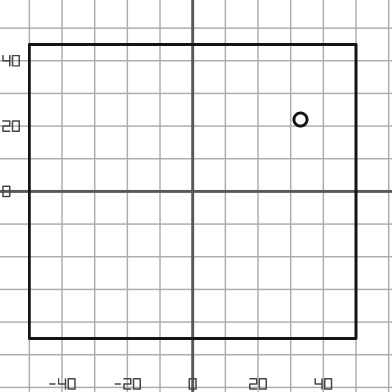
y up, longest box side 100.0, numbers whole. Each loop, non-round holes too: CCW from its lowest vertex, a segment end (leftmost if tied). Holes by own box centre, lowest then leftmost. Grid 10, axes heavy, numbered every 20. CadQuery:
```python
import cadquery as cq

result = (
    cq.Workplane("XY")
    .moveTo(-50.0, -45.0)
    .lineTo(50.0, -45.0)
    .lineTo(50.0, 45.0)
    .lineTo(-50.0, 45.0)
    .close()
    .moveTo(33.0, 22.0)
    .circle(2.0)
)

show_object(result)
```